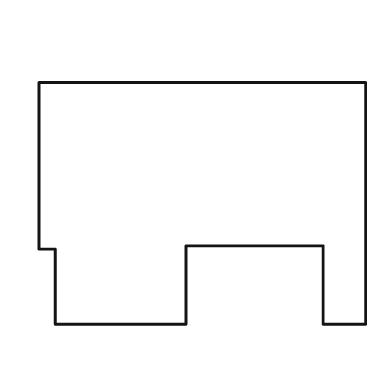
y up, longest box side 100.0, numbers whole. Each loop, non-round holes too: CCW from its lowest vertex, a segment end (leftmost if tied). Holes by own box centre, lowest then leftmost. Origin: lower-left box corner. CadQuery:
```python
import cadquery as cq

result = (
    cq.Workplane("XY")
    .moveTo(5.0, 0.0)
    .lineTo(45.0, 0.0)
    .lineTo(45.0, 24.0)
    .lineTo(87.0, 24.0)
    .lineTo(87.0, 0.0)
    .lineTo(100.0, 0.0)
    .lineTo(100.0, 74.0)
    .lineTo(0.0, 74.0)
    .lineTo(0.0, 23.0)
    .lineTo(5.0, 23.0)
    .close()
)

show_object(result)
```